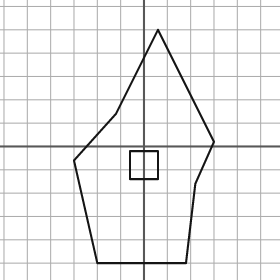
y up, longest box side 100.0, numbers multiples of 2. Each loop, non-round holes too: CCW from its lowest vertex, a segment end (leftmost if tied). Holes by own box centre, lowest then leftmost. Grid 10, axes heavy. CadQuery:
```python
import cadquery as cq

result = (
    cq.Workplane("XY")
    .moveTo(-20.0, -50.0)
    .lineTo(18.0, -50.0)
    .lineTo(22.0, -16.0)
    .lineTo(30.0, 2.0)
    .lineTo(6.0, 50.0)
    .lineTo(-12.0, 14.0)
    .lineTo(-30.0, -6.0)
    .close()
    .moveTo(-6.0, -14.0)
    .lineTo(6.0, -14.0)
    .lineTo(6.0, -2.0)
    .lineTo(-6.0, -2.0)
    .close()
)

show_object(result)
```